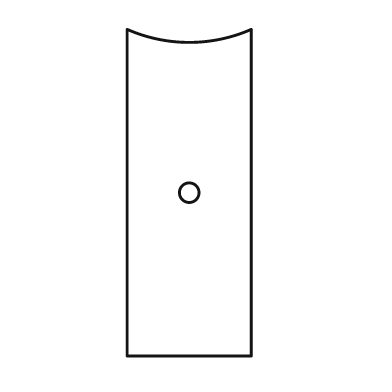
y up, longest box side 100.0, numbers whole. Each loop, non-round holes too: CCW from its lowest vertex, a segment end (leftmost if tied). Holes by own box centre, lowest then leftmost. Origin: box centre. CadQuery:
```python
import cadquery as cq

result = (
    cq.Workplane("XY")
    .moveTo(-19.0, -50.0)
    .lineTo(19.0, -50.0)
    .lineTo(19.0, 50.0)
    .threePointArc((0.0, 46.0), (-19.0, 50.0))
    .close()
    .moveTo(0.0, 0.0)
    .circle(3.0)
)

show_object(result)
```